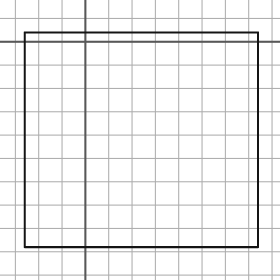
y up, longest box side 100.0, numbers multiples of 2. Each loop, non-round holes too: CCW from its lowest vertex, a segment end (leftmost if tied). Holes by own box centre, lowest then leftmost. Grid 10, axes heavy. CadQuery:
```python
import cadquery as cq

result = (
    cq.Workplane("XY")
    .moveTo(-26.0, -88.0)
    .lineTo(74.0, -88.0)
    .lineTo(74.0, 4.0)
    .lineTo(-26.0, 4.0)
    .close()
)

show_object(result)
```